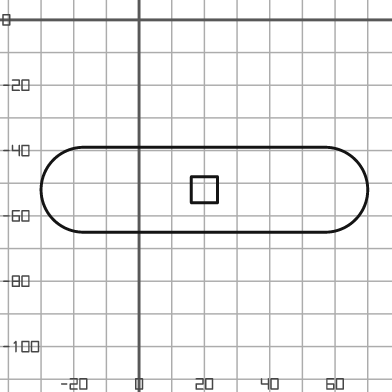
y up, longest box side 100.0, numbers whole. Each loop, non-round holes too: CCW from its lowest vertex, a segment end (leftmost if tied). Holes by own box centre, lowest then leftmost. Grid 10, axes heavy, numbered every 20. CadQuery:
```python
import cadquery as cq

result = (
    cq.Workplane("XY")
    .moveTo(-17.0, -65.0)
    .lineTo(57.0, -65.0)
    .threePointArc((70.0, -52.0), (57.0, -39.0))
    .lineTo(-17.0, -39.0)
    .threePointArc((-30.0, -52.0), (-17.0, -65.0))
    .close()
    .moveTo(16.0, -56.0)
    .lineTo(24.0, -56.0)
    .lineTo(24.0, -48.0)
    .lineTo(16.0, -48.0)
    .close()
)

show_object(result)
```